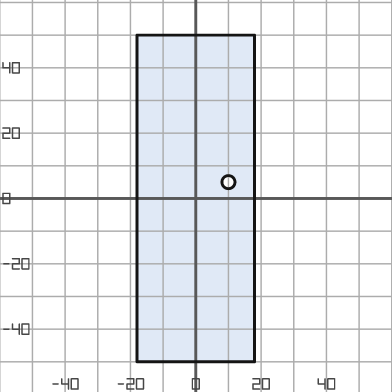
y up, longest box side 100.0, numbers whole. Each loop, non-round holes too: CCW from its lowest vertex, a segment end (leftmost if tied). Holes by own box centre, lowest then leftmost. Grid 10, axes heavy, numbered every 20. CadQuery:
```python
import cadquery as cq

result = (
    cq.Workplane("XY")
    .moveTo(-18.0, -50.0)
    .lineTo(18.0, -50.0)
    .lineTo(18.0, 50.0)
    .lineTo(-18.0, 50.0)
    .close()
    .moveTo(10.0, 5.0)
    .circle(2.0)
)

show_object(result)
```